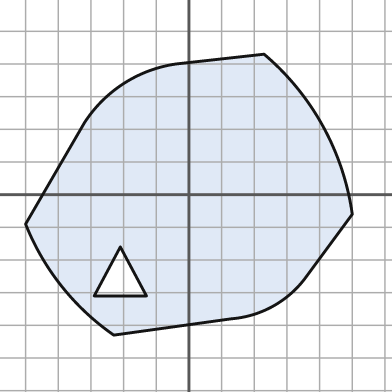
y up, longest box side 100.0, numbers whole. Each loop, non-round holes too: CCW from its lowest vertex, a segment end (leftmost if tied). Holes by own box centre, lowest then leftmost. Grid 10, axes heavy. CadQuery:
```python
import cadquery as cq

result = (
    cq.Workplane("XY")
    .moveTo(-23.0, -43.0)
    .lineTo(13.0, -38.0)
    .threePointArc((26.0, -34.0), (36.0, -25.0))
    .lineTo(50.0, -6.0)
    .threePointArc((41.0, 21.0), (23.0, 43.0))
    .lineTo(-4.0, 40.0)
    .threePointArc((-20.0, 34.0), (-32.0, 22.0))
    .lineTo(-50.0, -9.0)
    .threePointArc((-39.0, -28.0), (-23.0, -43.0))
    .close()
    .moveTo(-29.0, -31.0)
    .lineTo(-13.0, -31.0)
    .lineTo(-21.0, -16.0)
    .close()
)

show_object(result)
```